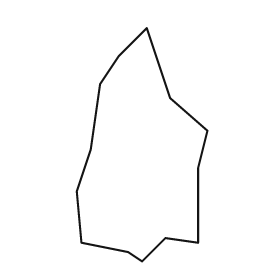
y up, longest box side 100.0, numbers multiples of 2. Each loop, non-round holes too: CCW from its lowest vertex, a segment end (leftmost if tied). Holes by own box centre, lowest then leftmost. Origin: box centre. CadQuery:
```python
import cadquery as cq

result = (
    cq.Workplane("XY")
    .moveTo(0.0, -50.0)
    .lineTo(10.0, -40.0)
    .lineTo(24.0, -42.0)
    .lineTo(24.0, -10.0)
    .lineTo(28.0, 6.0)
    .lineTo(12.0, 20.0)
    .lineTo(2.0, 50.0)
    .lineTo(-10.0, 38.0)
    .lineTo(-18.0, 26.0)
    .lineTo(-22.0, -2.0)
    .lineTo(-28.0, -20.0)
    .lineTo(-26.0, -42.0)
    .lineTo(-6.0, -46.0)
    .close()
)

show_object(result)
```